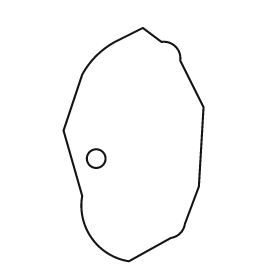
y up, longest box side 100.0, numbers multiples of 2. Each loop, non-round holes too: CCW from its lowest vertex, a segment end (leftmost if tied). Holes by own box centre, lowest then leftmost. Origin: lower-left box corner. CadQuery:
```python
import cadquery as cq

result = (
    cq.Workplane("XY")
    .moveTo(28.0, 0.0)
    .lineTo(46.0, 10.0)
    .threePointArc((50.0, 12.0), (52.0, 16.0))
    .lineTo(58.0, 32.0)
    .lineTo(60.0, 66.0)
    .lineTo(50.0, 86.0)
    .threePointArc((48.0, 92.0), (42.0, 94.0))
    .lineTo(34.0, 100.0)
    .lineTo(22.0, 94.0)
    .threePointArc((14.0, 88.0), (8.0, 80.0))
    .lineTo(0.0, 56.0)
    .lineTo(8.0, 28.0)
    .threePointArc((12.0, 10.0), (28.0, 0.0))
    .close()
    .moveTo(14.0, 44.0)
    .circle(4.0)
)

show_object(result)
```